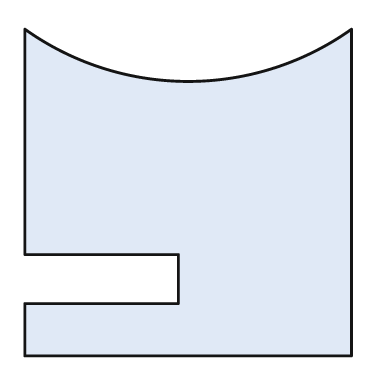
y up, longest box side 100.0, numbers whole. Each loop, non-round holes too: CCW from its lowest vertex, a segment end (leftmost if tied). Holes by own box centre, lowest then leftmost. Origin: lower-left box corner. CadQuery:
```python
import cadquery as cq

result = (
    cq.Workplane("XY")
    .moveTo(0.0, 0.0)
    .lineTo(100.0, 0.0)
    .lineTo(100.0, 100.0)
    .threePointArc((50.0, 84.0), (0.0, 100.0))
    .lineTo(0.0, 31.0)
    .lineTo(47.0, 31.0)
    .lineTo(47.0, 16.0)
    .lineTo(0.0, 16.0)
    .close()
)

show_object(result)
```